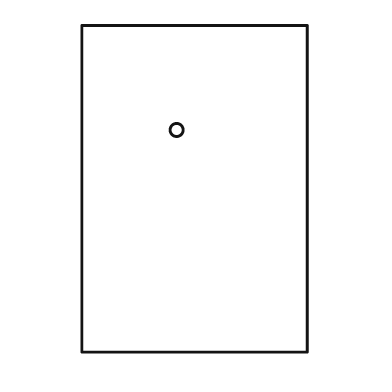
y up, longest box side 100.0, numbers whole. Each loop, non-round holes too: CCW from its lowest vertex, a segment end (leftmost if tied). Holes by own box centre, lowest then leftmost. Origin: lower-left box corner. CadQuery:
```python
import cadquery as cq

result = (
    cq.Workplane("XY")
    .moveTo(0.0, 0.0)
    .lineTo(69.0, 0.0)
    .lineTo(69.0, 100.0)
    .lineTo(0.0, 100.0)
    .close()
    .moveTo(29.0, 68.0)
    .circle(2.0)
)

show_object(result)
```